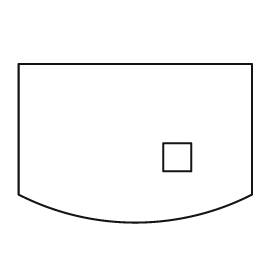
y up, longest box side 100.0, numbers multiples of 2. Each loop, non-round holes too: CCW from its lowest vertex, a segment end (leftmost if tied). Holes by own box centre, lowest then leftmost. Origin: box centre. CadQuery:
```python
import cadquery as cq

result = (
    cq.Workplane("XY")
    .moveTo(-50.0, -22.0)
    .threePointArc((0.0, -34.0), (50.0, -22.0))
    .lineTo(50.0, 34.0)
    .lineTo(-50.0, 34.0)
    .close()
    .moveTo(12.0, -12.0)
    .lineTo(24.0, -12.0)
    .lineTo(24.0, 0.0)
    .lineTo(12.0, 0.0)
    .close()
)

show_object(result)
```